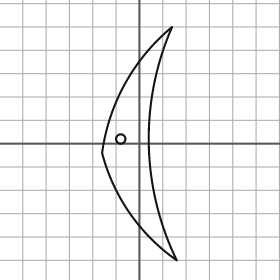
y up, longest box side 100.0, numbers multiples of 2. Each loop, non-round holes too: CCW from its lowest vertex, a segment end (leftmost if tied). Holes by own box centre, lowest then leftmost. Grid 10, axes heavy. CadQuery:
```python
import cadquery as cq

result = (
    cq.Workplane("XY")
    .moveTo(16.0, -50.0)
    .threePointArc((4.0, 0.0), (14.0, 50.0))
    .threePointArc((-6.0, 26.0), (-16.0, -4.0))
    .threePointArc((-4.0, -30.0), (16.0, -50.0))
    .close()
    .moveTo(-8.0, 2.0)
    .circle(2.0)
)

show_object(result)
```